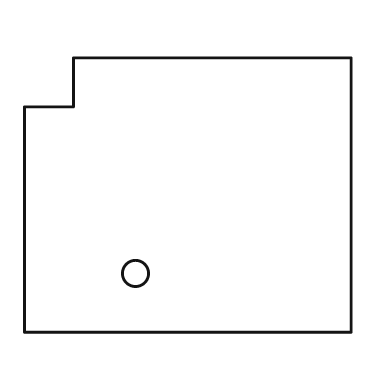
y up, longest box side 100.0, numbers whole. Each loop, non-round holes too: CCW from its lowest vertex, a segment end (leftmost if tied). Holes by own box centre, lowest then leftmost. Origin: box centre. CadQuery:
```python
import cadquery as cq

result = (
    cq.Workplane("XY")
    .moveTo(-50.0, -42.0)
    .lineTo(50.0, -42.0)
    .lineTo(50.0, 42.0)
    .lineTo(-35.0, 42.0)
    .lineTo(-35.0, 27.0)
    .lineTo(-50.0, 27.0)
    .close()
    .moveTo(-16.0, -24.0)
    .circle(4.0)
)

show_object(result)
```